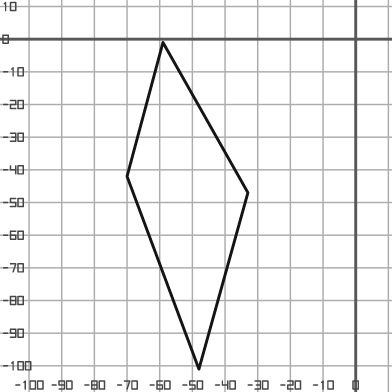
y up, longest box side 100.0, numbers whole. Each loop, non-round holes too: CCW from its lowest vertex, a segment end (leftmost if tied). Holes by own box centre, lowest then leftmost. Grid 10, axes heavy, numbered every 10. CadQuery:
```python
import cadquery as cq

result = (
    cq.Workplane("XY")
    .moveTo(-48.0, -101.0)
    .lineTo(-33.0, -47.0)
    .lineTo(-59.0, -1.0)
    .lineTo(-70.0, -42.0)
    .close()
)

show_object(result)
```